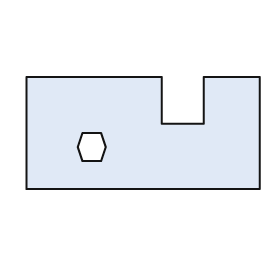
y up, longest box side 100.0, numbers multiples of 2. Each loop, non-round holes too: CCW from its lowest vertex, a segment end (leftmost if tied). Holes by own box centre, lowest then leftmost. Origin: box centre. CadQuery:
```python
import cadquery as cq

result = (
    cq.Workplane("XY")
    .moveTo(-50.0, -24.0)
    .lineTo(50.0, -24.0)
    .lineTo(50.0, 24.0)
    .lineTo(26.0, 24.0)
    .lineTo(26.0, 4.0)
    .lineTo(8.0, 4.0)
    .lineTo(8.0, 24.0)
    .lineTo(-50.0, 24.0)
    .close()
    .moveTo(-26.0, -12.0)
    .lineTo(-18.0, -12.0)
    .lineTo(-16.0, -6.0)
    .lineTo(-18.0, 0.0)
    .lineTo(-26.0, 0.0)
    .lineTo(-28.0, -6.0)
    .close()
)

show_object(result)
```